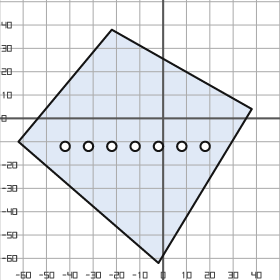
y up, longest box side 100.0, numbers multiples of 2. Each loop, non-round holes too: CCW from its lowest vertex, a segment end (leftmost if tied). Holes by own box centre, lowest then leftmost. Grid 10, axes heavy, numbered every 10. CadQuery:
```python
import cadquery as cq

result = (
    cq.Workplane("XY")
    .moveTo(-2.0, -62.0)
    .lineTo(38.0, 4.0)
    .lineTo(-22.0, 38.0)
    .lineTo(-62.0, -10.0)
    .close()
    .moveTo(-42.0, -12.0)
    .circle(2.0)
    .moveTo(-32.0, -12.0)
    .circle(2.0)
    .moveTo(-22.0, -12.0)
    .circle(2.0)
    .moveTo(-12.0, -12.0)
    .circle(2.0)
    .moveTo(-2.0, -12.0)
    .circle(2.0)
    .moveTo(8.0, -12.0)
    .circle(2.0)
    .moveTo(18.0, -12.0)
    .circle(2.0)
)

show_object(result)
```